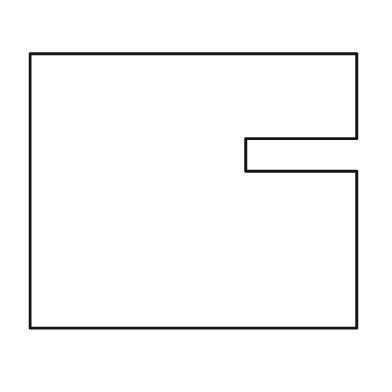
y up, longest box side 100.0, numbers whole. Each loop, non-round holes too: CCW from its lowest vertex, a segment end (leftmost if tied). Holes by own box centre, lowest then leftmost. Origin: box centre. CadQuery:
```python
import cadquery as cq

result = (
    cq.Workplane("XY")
    .moveTo(-50.0, -42.0)
    .lineTo(50.0, -42.0)
    .lineTo(50.0, 6.0)
    .lineTo(16.0, 6.0)
    .lineTo(16.0, 16.0)
    .lineTo(50.0, 16.0)
    .lineTo(50.0, 42.0)
    .lineTo(-50.0, 42.0)
    .close()
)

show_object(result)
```